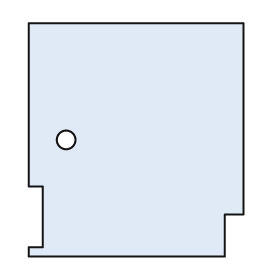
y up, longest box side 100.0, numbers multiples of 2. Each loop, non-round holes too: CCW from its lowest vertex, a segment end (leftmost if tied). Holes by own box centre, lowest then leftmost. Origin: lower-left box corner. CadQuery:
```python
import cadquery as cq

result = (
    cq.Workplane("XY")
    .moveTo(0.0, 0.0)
    .lineTo(84.0, 0.0)
    .lineTo(84.0, 18.0)
    .lineTo(92.0, 18.0)
    .lineTo(92.0, 100.0)
    .lineTo(0.0, 100.0)
    .lineTo(0.0, 30.0)
    .lineTo(6.0, 30.0)
    .lineTo(6.0, 4.0)
    .lineTo(0.0, 4.0)
    .close()
    .moveTo(16.0, 50.0)
    .circle(4.0)
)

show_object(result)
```